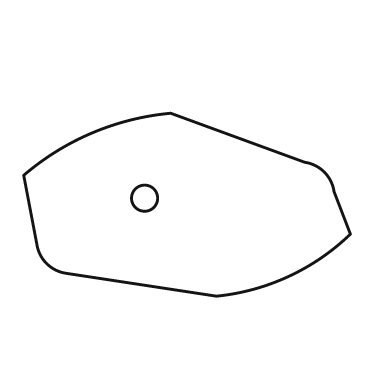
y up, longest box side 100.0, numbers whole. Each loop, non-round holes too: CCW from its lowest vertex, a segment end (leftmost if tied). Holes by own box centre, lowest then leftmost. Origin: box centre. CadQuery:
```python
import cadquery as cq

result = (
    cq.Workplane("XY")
    .moveTo(9.0, -28.0)
    .threePointArc((31.0, -22.0), (50.0, -9.0))
    .lineTo(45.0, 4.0)
    .threePointArc((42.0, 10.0), (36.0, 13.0))
    .lineTo(-5.0, 28.0)
    .threePointArc((-29.0, 22.0), (-50.0, 9.0))
    .lineTo(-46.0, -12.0)
    .threePointArc((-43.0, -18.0), (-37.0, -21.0))
    .close()
    .moveTo(-13.0, 2.0)
    .circle(4.0)
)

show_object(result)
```